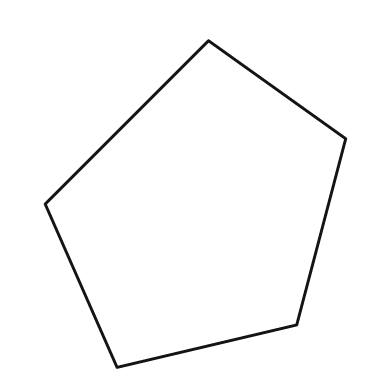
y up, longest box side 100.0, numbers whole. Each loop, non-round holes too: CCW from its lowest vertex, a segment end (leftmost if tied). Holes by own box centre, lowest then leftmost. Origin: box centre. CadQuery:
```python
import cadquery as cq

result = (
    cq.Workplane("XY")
    .moveTo(-24.0, -50.0)
    .lineTo(31.0, -37.0)
    .lineTo(46.0, 20.0)
    .lineTo(4.0, 50.0)
    .lineTo(-46.0, 0.0)
    .close()
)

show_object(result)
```